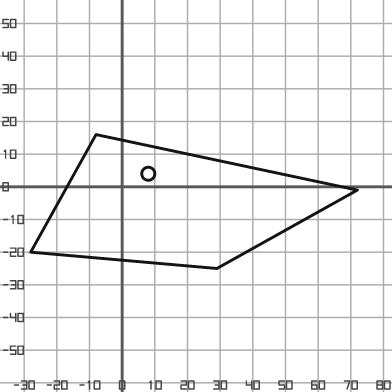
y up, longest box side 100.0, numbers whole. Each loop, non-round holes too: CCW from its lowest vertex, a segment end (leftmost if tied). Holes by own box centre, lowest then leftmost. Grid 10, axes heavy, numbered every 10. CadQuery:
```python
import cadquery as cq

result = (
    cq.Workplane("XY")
    .moveTo(29.0, -25.0)
    .lineTo(72.0, -1.0)
    .lineTo(-8.0, 16.0)
    .lineTo(-28.0, -20.0)
    .close()
    .moveTo(8.0, 4.0)
    .circle(2.0)
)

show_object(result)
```